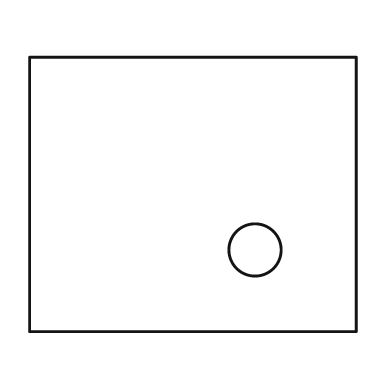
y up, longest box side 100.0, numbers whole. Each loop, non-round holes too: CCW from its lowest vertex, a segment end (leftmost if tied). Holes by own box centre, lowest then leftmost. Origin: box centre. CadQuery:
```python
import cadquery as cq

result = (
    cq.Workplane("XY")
    .moveTo(-50.0, -42.0)
    .lineTo(50.0, -42.0)
    .lineTo(50.0, 42.0)
    .lineTo(-50.0, 42.0)
    .close()
    .moveTo(19.0, -17.0)
    .circle(8.0)
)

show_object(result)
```